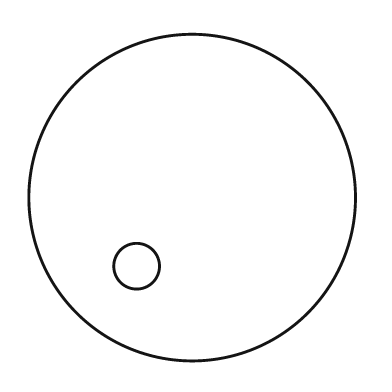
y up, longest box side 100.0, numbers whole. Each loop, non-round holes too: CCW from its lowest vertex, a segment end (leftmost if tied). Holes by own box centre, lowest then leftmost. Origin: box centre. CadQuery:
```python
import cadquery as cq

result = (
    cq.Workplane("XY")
    .moveTo(0.0, 0.0)
    .circle(50.0)
    .moveTo(-17.0, -21.0)
    .circle(7.0)
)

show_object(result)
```